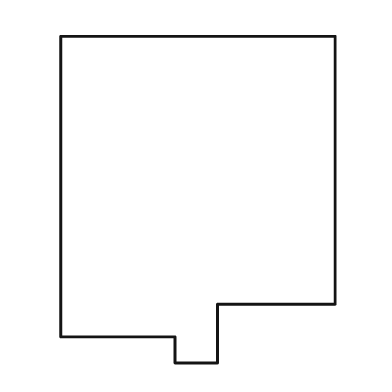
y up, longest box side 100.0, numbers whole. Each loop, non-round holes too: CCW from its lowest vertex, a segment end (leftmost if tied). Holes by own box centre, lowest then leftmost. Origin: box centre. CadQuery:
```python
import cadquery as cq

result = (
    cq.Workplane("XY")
    .moveTo(-7.0, -50.0)
    .lineTo(6.0, -50.0)
    .lineTo(6.0, -32.0)
    .lineTo(42.0, -32.0)
    .lineTo(42.0, 50.0)
    .lineTo(-42.0, 50.0)
    .lineTo(-42.0, -42.0)
    .lineTo(-7.0, -42.0)
    .close()
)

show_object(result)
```